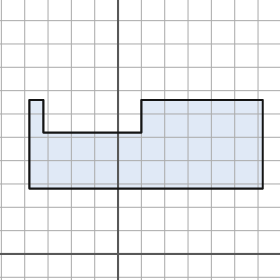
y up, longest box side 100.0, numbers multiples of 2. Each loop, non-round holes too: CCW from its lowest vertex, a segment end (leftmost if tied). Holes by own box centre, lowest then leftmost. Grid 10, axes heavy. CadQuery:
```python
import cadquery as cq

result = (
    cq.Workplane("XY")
    .moveTo(-38.0, 28.0)
    .lineTo(62.0, 28.0)
    .lineTo(62.0, 66.0)
    .lineTo(10.0, 66.0)
    .lineTo(10.0, 52.0)
    .lineTo(-32.0, 52.0)
    .lineTo(-32.0, 66.0)
    .lineTo(-38.0, 66.0)
    .close()
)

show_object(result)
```